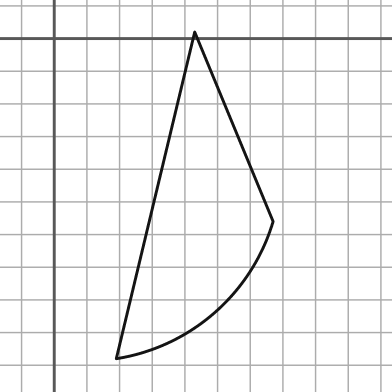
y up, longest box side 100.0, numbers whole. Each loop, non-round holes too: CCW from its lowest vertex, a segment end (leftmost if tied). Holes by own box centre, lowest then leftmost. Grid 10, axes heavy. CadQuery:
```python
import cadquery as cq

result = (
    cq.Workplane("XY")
    .moveTo(19.0, -98.0)
    .threePointArc((49.0, -84.0), (67.0, -56.0))
    .lineTo(43.0, 2.0)
    .close()
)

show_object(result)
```